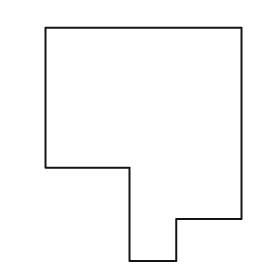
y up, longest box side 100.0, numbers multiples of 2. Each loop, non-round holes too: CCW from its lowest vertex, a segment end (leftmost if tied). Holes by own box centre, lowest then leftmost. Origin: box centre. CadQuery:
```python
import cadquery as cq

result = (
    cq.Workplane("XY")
    .moveTo(-6.0, -50.0)
    .lineTo(14.0, -50.0)
    .lineTo(14.0, -32.0)
    .lineTo(42.0, -32.0)
    .lineTo(42.0, 50.0)
    .lineTo(-42.0, 50.0)
    .lineTo(-42.0, -10.0)
    .lineTo(-6.0, -10.0)
    .close()
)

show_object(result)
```